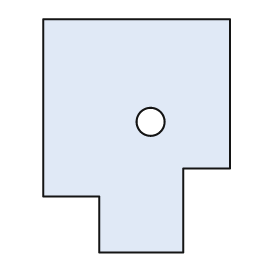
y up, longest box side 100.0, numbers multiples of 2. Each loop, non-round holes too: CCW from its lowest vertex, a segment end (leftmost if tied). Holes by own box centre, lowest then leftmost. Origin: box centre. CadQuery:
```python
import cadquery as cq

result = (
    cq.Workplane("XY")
    .moveTo(-16.0, -50.0)
    .lineTo(20.0, -50.0)
    .lineTo(20.0, -14.0)
    .lineTo(40.0, -14.0)
    .lineTo(40.0, 50.0)
    .lineTo(-40.0, 50.0)
    .lineTo(-40.0, -26.0)
    .lineTo(-16.0, -26.0)
    .close()
    .moveTo(6.0, 6.0)
    .circle(6.0)
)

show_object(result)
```